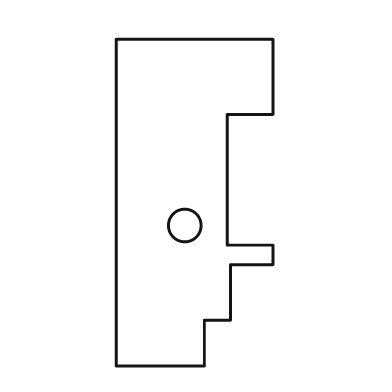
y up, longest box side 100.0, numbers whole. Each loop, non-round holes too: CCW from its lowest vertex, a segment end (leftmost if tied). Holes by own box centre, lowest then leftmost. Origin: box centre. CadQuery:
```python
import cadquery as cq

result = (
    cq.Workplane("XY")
    .moveTo(-24.0, -50.0)
    .lineTo(3.0, -50.0)
    .lineTo(3.0, -36.0)
    .lineTo(11.0, -36.0)
    .lineTo(11.0, -19.0)
    .lineTo(24.0, -19.0)
    .lineTo(24.0, -13.0)
    .lineTo(10.0, -13.0)
    .lineTo(10.0, 27.0)
    .lineTo(24.0, 27.0)
    .lineTo(24.0, 50.0)
    .lineTo(-24.0, 50.0)
    .close()
    .moveTo(-3.0, -7.0)
    .circle(5.0)
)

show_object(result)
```